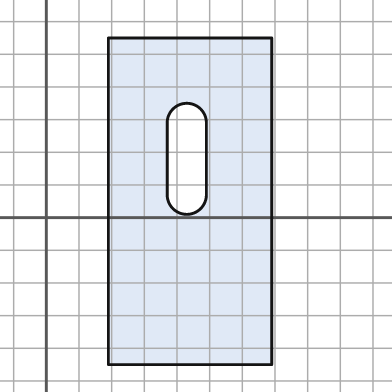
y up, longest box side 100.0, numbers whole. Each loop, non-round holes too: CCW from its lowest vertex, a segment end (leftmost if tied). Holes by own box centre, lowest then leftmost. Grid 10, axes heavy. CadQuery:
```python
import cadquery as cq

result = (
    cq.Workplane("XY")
    .moveTo(19.0, -45.0)
    .lineTo(69.0, -45.0)
    .lineTo(69.0, 55.0)
    .lineTo(19.0, 55.0)
    .close()
    .moveTo(37.0, 7.0)
    .threePointArc((43.0, 1.0), (49.0, 7.0))
    .lineTo(49.0, 29.0)
    .threePointArc((43.0, 35.0), (37.0, 29.0))
    .close()
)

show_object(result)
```